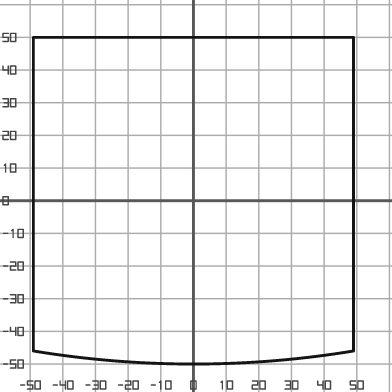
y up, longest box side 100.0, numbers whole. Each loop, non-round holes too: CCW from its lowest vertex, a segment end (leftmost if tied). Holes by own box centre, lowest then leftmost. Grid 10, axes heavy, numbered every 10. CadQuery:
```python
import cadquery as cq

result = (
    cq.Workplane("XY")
    .moveTo(-49.0, -46.0)
    .threePointArc((0.0, -50.0), (49.0, -46.0))
    .lineTo(49.0, 50.0)
    .lineTo(-49.0, 50.0)
    .close()
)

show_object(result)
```